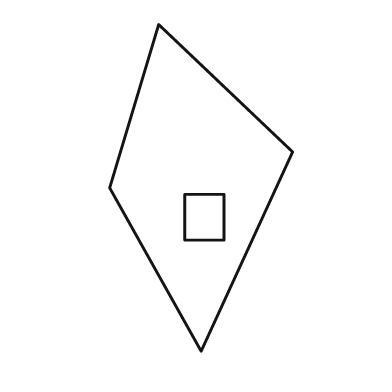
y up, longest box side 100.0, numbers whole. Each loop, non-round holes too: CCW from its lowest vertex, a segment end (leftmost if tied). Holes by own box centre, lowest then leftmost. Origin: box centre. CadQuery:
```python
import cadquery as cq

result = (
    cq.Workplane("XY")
    .moveTo(0.0, -50.0)
    .lineTo(28.0, 11.0)
    .lineTo(-13.0, 50.0)
    .lineTo(-28.0, 0.0)
    .close()
    .moveTo(-5.0, -16.0)
    .lineTo(7.0, -16.0)
    .lineTo(7.0, -2.0)
    .lineTo(-5.0, -2.0)
    .close()
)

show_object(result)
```